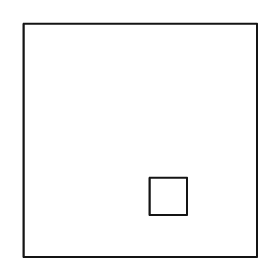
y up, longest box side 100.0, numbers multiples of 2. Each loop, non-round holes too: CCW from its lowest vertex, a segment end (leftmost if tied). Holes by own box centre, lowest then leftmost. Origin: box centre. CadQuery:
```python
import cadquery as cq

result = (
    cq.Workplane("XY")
    .moveTo(-50.0, -50.0)
    .lineTo(50.0, -50.0)
    .lineTo(50.0, 50.0)
    .lineTo(-50.0, 50.0)
    .close()
    .moveTo(4.0, -32.0)
    .lineTo(20.0, -32.0)
    .lineTo(20.0, -16.0)
    .lineTo(4.0, -16.0)
    .close()
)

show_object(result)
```